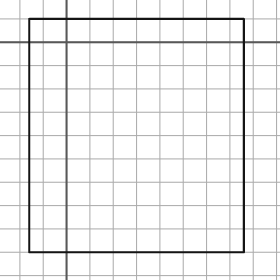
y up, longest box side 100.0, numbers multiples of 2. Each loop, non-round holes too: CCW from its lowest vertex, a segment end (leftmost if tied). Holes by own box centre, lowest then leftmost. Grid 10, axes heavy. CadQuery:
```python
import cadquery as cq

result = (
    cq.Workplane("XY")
    .moveTo(-16.0, -90.0)
    .lineTo(76.0, -90.0)
    .lineTo(76.0, 10.0)
    .lineTo(-16.0, 10.0)
    .close()
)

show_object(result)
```